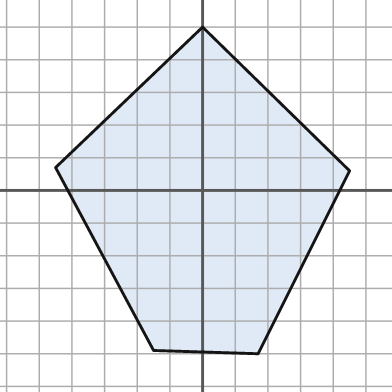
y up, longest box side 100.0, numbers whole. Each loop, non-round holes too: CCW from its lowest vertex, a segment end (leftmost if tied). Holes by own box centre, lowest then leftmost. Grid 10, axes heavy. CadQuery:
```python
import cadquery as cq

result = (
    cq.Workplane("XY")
    .moveTo(17.0, -50.0)
    .lineTo(45.0, 6.0)
    .lineTo(0.0, 50.0)
    .lineTo(-45.0, 7.0)
    .lineTo(-15.0, -49.0)
    .close()
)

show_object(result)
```